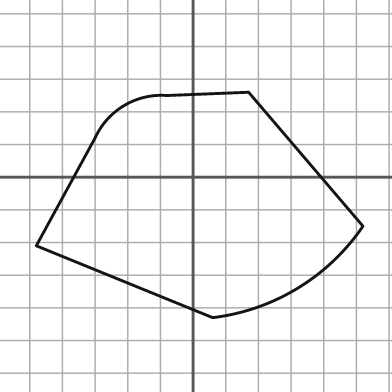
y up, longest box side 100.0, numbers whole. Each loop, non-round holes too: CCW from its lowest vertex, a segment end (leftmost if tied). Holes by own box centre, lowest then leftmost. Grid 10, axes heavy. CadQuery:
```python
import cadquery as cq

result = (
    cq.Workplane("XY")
    .moveTo(6.0, -43.0)
    .threePointArc((32.0, -34.0), (52.0, -15.0))
    .lineTo(17.0, 26.0)
    .lineTo(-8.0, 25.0)
    .threePointArc((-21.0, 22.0), (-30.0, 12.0))
    .lineTo(-48.0, -21.0)
    .close()
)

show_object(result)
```